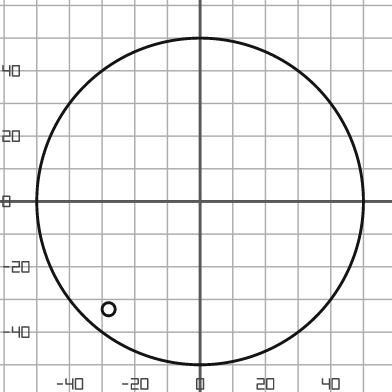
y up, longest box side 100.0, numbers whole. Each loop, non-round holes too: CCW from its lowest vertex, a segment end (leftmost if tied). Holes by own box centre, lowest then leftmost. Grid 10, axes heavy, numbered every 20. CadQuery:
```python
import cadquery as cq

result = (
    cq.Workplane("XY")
    .moveTo(0.0, 0.0)
    .circle(50.0)
    .moveTo(-28.0, -33.0)
    .circle(2.0)
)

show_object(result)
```